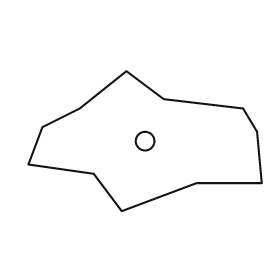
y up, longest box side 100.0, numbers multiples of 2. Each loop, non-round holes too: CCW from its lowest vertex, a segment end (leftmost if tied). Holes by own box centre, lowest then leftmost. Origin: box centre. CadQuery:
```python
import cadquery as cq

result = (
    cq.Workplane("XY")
    .moveTo(-10.0, -30.0)
    .lineTo(22.0, -18.0)
    .lineTo(50.0, -18.0)
    .lineTo(48.0, 4.0)
    .lineTo(42.0, 14.0)
    .lineTo(8.0, 18.0)
    .lineTo(-8.0, 30.0)
    .lineTo(-28.0, 14.0)
    .lineTo(-44.0, 6.0)
    .lineTo(-50.0, -10.0)
    .lineTo(-22.0, -14.0)
    .close()
    .moveTo(0.0, 0.0)
    .circle(4.0)
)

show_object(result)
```